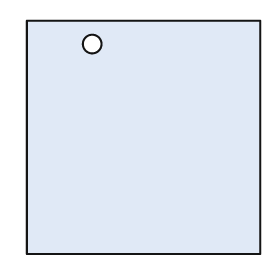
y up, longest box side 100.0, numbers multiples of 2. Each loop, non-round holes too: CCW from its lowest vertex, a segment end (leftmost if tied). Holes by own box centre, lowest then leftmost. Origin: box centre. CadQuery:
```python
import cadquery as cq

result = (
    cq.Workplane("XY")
    .moveTo(-50.0, -50.0)
    .lineTo(50.0, -50.0)
    .lineTo(50.0, 50.0)
    .lineTo(-50.0, 50.0)
    .close()
    .moveTo(-22.0, 40.0)
    .circle(4.0)
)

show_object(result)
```